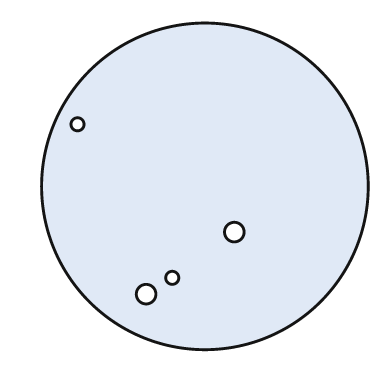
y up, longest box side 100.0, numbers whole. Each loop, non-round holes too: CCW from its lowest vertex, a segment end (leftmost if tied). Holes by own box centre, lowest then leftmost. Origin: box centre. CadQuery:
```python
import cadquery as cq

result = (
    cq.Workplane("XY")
    .moveTo(0.0, 0.0)
    .circle(50.0)
    .moveTo(-18.0, -33.0)
    .circle(3.0)
    .moveTo(-10.0, -28.0)
    .circle(2.0)
    .moveTo(9.0, -14.0)
    .circle(3.0)
    .moveTo(-39.0, 19.0)
    .circle(2.0)
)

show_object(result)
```